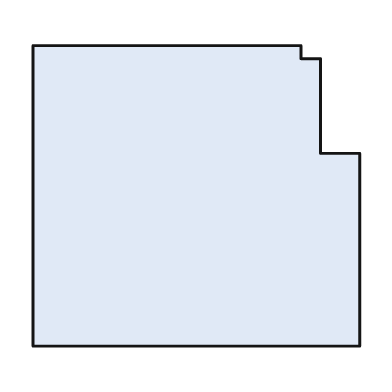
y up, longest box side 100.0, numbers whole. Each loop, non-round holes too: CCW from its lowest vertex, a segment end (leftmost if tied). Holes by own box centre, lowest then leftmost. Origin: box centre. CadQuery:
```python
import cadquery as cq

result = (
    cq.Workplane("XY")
    .moveTo(-50.0, -46.0)
    .lineTo(50.0, -46.0)
    .lineTo(50.0, 13.0)
    .lineTo(38.0, 13.0)
    .lineTo(38.0, 42.0)
    .lineTo(32.0, 42.0)
    .lineTo(32.0, 46.0)
    .lineTo(-50.0, 46.0)
    .close()
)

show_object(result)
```